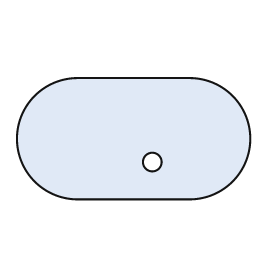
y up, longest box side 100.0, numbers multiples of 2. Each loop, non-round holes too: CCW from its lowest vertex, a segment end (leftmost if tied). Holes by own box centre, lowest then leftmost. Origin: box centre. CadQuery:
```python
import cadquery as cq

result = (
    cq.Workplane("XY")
    .moveTo(-24.0, -26.0)
    .lineTo(24.0, -26.0)
    .threePointArc((50.0, 0.0), (24.0, 26.0))
    .lineTo(-24.0, 26.0)
    .threePointArc((-50.0, 0.0), (-24.0, -26.0))
    .close()
    .moveTo(8.0, -10.0)
    .circle(4.0)
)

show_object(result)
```